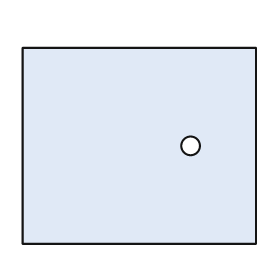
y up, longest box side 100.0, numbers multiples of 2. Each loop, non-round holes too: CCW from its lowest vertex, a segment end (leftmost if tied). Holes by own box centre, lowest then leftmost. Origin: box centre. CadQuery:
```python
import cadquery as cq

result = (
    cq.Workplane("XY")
    .moveTo(-50.0, -42.0)
    .lineTo(50.0, -42.0)
    .lineTo(50.0, 42.0)
    .lineTo(-50.0, 42.0)
    .close()
    .moveTo(22.0, 0.0)
    .circle(4.0)
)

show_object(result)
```